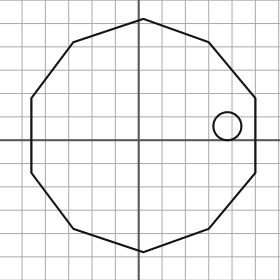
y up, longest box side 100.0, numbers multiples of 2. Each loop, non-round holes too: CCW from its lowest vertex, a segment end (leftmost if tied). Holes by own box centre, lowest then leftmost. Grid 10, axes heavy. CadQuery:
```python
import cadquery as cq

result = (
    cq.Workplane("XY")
    .moveTo(2.0, -48.0)
    .lineTo(30.0, -38.0)
    .lineTo(50.0, -14.0)
    .lineTo(50.0, 18.0)
    .lineTo(30.0, 42.0)
    .lineTo(2.0, 52.0)
    .lineTo(-28.0, 42.0)
    .lineTo(-46.0, 18.0)
    .lineTo(-46.0, -14.0)
    .lineTo(-28.0, -38.0)
    .close()
    .moveTo(38.0, 6.0)
    .circle(6.0)
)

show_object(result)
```